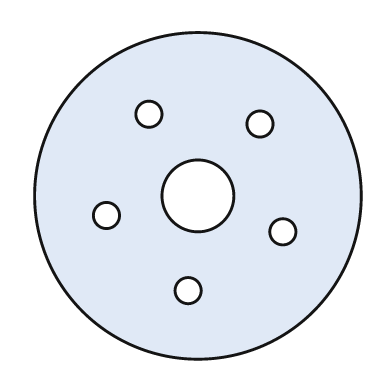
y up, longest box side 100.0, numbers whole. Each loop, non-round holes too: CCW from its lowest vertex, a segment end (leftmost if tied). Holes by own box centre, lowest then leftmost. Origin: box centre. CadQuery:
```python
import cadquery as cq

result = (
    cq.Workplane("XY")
    .moveTo(0.0, 0.0)
    .circle(50.0)
    .moveTo(-3.0, -29.0)
    .circle(4.0)
    .moveTo(26.0, -11.0)
    .circle(4.0)
    .moveTo(-28.0, -6.0)
    .circle(4.0)
    .moveTo(0.0, 0.0)
    .circle(11.0)
    .moveTo(19.0, 22.0)
    .circle(4.0)
    .moveTo(-15.0, 25.0)
    .circle(4.0)
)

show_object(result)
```